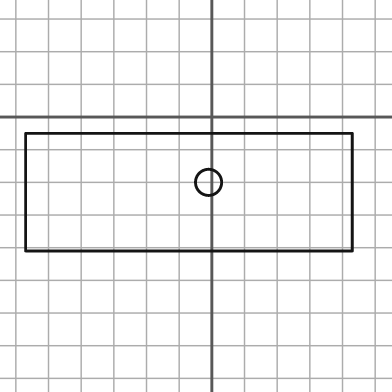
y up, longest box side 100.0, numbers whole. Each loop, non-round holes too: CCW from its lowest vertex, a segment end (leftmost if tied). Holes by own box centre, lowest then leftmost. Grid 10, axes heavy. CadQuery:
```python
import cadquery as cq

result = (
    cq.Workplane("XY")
    .moveTo(-57.0, -41.0)
    .lineTo(43.0, -41.0)
    .lineTo(43.0, -5.0)
    .lineTo(-57.0, -5.0)
    .close()
    .moveTo(-1.0, -20.0)
    .circle(4.0)
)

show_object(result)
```